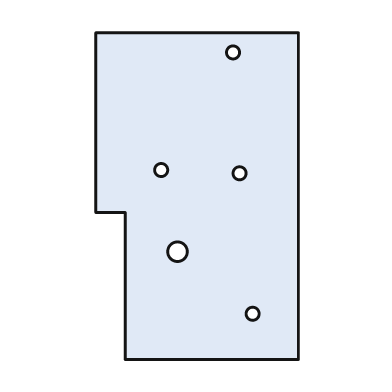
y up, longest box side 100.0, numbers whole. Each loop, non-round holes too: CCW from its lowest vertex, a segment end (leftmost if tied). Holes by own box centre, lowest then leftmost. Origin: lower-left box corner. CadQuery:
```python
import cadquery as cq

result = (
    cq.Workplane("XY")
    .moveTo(9.0, 0.0)
    .lineTo(62.0, 0.0)
    .lineTo(62.0, 100.0)
    .lineTo(0.0, 100.0)
    .lineTo(0.0, 45.0)
    .lineTo(9.0, 45.0)
    .close()
    .moveTo(48.0, 14.0)
    .circle(2.0)
    .moveTo(25.0, 33.0)
    .circle(3.0)
    .moveTo(44.0, 57.0)
    .circle(2.0)
    .moveTo(20.0, 58.0)
    .circle(2.0)
    .moveTo(42.0, 94.0)
    .circle(2.0)
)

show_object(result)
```